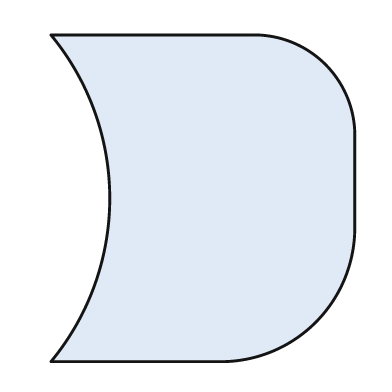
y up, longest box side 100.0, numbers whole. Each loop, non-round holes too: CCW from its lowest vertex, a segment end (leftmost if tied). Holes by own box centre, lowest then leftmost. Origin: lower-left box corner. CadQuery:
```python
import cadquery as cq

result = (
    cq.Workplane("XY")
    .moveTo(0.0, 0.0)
    .lineTo(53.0, 0.0)
    .threePointArc((81.0, 12.0), (93.0, 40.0))
    .lineTo(93.0, 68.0)
    .threePointArc((84.0, 91.0), (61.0, 100.0))
    .lineTo(0.0, 100.0)
    .threePointArc((18.0, 50.0), (0.0, 0.0))
    .close()
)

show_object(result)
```